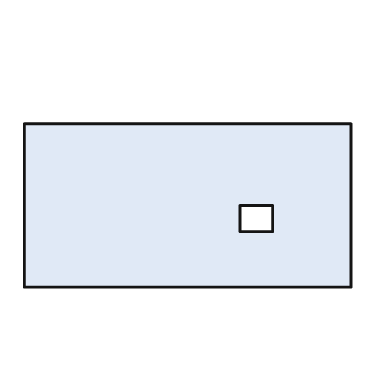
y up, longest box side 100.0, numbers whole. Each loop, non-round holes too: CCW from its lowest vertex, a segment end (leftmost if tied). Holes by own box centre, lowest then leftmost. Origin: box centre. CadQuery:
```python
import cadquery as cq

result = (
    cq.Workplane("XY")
    .moveTo(-50.0, -25.0)
    .lineTo(50.0, -25.0)
    .lineTo(50.0, 25.0)
    .lineTo(-50.0, 25.0)
    .close()
    .moveTo(16.0, -8.0)
    .lineTo(26.0, -8.0)
    .lineTo(26.0, 0.0)
    .lineTo(16.0, 0.0)
    .close()
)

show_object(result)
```